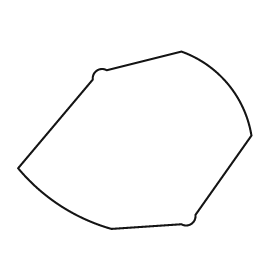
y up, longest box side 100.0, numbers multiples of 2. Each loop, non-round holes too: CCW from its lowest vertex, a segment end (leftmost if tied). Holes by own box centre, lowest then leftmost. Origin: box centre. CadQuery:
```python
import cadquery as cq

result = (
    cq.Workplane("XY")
    .moveTo(-10.0, -38.0)
    .lineTo(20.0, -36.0)
    .threePointArc((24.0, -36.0), (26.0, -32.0))
    .lineTo(50.0, 2.0)
    .threePointArc((40.0, 24.0), (20.0, 38.0))
    .lineTo(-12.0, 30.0)
    .threePointArc((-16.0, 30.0), (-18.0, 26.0))
    .lineTo(-50.0, -12.0)
    .threePointArc((-32.0, -28.0), (-10.0, -38.0))
    .close()
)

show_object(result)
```